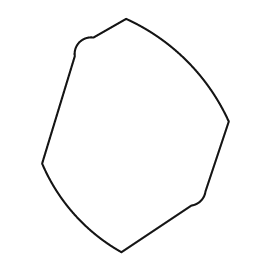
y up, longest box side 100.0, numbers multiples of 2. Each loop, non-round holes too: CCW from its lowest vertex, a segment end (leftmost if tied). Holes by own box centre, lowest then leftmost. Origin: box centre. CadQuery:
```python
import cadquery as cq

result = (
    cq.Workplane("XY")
    .moveTo(-6.0, -50.0)
    .lineTo(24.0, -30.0)
    .threePointArc((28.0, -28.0), (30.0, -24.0))
    .lineTo(40.0, 6.0)
    .threePointArc((22.0, 32.0), (-4.0, 50.0))
    .lineTo(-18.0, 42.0)
    .threePointArc((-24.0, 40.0), (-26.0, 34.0))
    .lineTo(-40.0, -12.0)
    .threePointArc((-26.0, -34.0), (-6.0, -50.0))
    .close()
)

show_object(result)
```